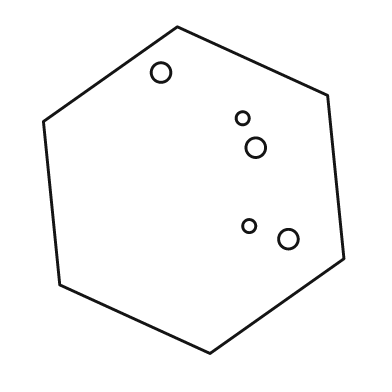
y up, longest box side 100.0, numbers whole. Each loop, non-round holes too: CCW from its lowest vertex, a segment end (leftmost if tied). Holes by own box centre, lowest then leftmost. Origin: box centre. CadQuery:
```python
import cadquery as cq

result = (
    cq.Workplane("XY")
    .moveTo(5.0, -50.0)
    .lineTo(46.0, -21.0)
    .lineTo(41.0, 29.0)
    .lineTo(-5.0, 50.0)
    .lineTo(-46.0, 21.0)
    .lineTo(-41.0, -29.0)
    .close()
    .moveTo(29.0, -15.0)
    .circle(3.0)
    .moveTo(17.0, -11.0)
    .circle(2.0)
    .moveTo(19.0, 13.0)
    .circle(3.0)
    .moveTo(15.0, 22.0)
    .circle(2.0)
    .moveTo(-10.0, 36.0)
    .circle(3.0)
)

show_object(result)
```